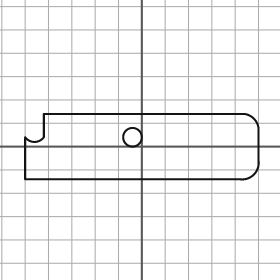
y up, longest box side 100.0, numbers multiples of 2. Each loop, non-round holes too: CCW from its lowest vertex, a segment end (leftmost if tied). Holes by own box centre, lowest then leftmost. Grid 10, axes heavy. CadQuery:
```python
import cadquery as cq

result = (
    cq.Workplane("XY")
    .moveTo(-50.0, -14.0)
    .lineTo(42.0, -14.0)
    .threePointArc((48.0, -12.0), (50.0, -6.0))
    .lineTo(50.0, 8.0)
    .threePointArc((48.0, 12.0), (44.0, 14.0))
    .lineTo(-42.0, 14.0)
    .lineTo(-42.0, 4.0)
    .threePointArc((-46.0, 2.0), (-50.0, 4.0))
    .close()
    .moveTo(-4.0, 4.0)
    .circle(4.0)
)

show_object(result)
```